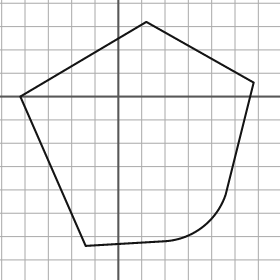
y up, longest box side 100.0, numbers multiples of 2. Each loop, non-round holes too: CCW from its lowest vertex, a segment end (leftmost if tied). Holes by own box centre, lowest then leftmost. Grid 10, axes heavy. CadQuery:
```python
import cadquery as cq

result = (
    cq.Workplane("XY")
    .moveTo(-14.0, -64.0)
    .lineTo(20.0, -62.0)
    .threePointArc((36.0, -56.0), (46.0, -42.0))
    .lineTo(58.0, 6.0)
    .lineTo(12.0, 32.0)
    .lineTo(-42.0, 0.0)
    .close()
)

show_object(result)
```